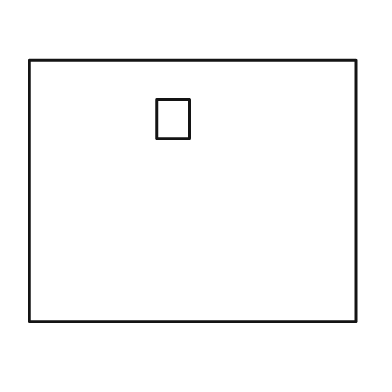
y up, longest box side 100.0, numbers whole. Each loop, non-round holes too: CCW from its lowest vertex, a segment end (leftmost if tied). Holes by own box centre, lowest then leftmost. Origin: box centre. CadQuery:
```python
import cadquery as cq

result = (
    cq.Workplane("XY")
    .moveTo(-50.0, -40.0)
    .lineTo(50.0, -40.0)
    .lineTo(50.0, 40.0)
    .lineTo(-50.0, 40.0)
    .close()
    .moveTo(-11.0, 16.0)
    .lineTo(-1.0, 16.0)
    .lineTo(-1.0, 28.0)
    .lineTo(-11.0, 28.0)
    .close()
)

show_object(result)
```